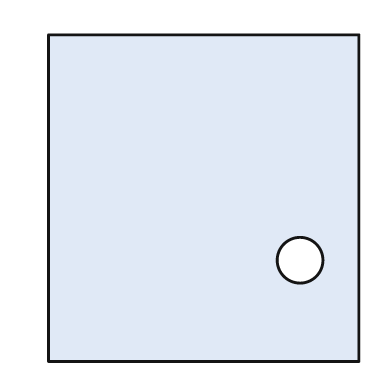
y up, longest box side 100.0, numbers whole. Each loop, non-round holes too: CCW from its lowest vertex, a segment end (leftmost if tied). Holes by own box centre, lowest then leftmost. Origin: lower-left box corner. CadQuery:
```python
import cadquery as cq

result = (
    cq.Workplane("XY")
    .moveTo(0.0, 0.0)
    .lineTo(95.0, 0.0)
    .lineTo(95.0, 100.0)
    .lineTo(0.0, 100.0)
    .close()
    .moveTo(77.0, 31.0)
    .circle(7.0)
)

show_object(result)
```